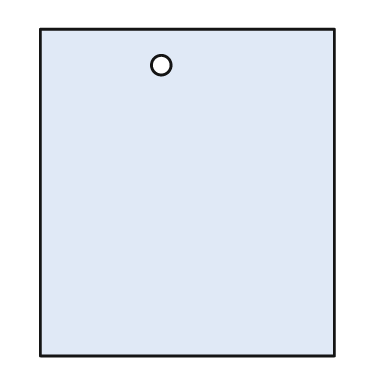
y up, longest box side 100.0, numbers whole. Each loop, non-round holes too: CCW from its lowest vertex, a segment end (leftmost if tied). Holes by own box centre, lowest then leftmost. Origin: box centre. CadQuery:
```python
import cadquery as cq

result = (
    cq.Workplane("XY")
    .moveTo(-45.0, -50.0)
    .lineTo(45.0, -50.0)
    .lineTo(45.0, 50.0)
    .lineTo(-45.0, 50.0)
    .close()
    .moveTo(-8.0, 39.0)
    .circle(3.0)
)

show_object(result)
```